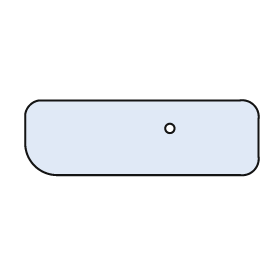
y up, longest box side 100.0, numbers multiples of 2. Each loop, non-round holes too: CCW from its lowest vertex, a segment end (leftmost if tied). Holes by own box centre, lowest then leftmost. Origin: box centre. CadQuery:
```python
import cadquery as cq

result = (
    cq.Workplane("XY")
    .moveTo(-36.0, -16.0)
    .lineTo(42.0, -16.0)
    .threePointArc((48.0, -14.0), (50.0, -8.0))
    .lineTo(50.0, 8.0)
    .threePointArc((48.0, 14.0), (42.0, 16.0))
    .lineTo(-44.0, 16.0)
    .threePointArc((-48.0, 14.0), (-50.0, 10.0))
    .lineTo(-50.0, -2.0)
    .threePointArc((-46.0, -12.0), (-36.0, -16.0))
    .close()
    .moveTo(12.0, 4.0)
    .circle(2.0)
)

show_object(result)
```